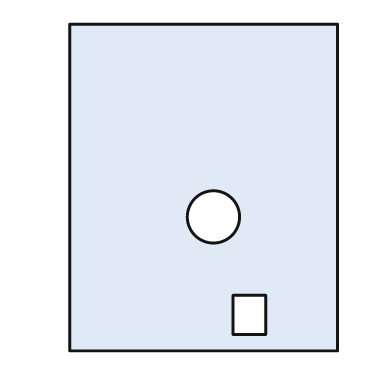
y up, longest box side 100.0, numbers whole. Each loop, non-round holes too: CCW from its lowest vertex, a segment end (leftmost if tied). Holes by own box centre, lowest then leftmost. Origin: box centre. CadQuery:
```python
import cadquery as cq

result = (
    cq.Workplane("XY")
    .moveTo(-41.0, -50.0)
    .lineTo(41.0, -50.0)
    .lineTo(41.0, 50.0)
    .lineTo(-41.0, 50.0)
    .close()
    .moveTo(9.0, -45.0)
    .lineTo(19.0, -45.0)
    .lineTo(19.0, -33.0)
    .lineTo(9.0, -33.0)
    .close()
    .moveTo(3.0, -9.0)
    .circle(8.0)
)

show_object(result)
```